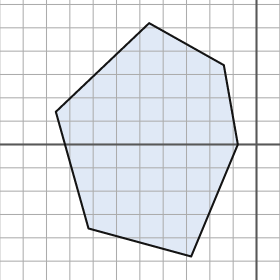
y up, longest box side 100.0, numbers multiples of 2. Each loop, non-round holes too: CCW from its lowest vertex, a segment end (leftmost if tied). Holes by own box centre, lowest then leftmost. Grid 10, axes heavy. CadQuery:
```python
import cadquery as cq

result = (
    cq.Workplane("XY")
    .moveTo(-28.0, -48.0)
    .lineTo(-8.0, 0.0)
    .lineTo(-14.0, 34.0)
    .lineTo(-46.0, 52.0)
    .lineTo(-86.0, 14.0)
    .lineTo(-72.0, -36.0)
    .close()
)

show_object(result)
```